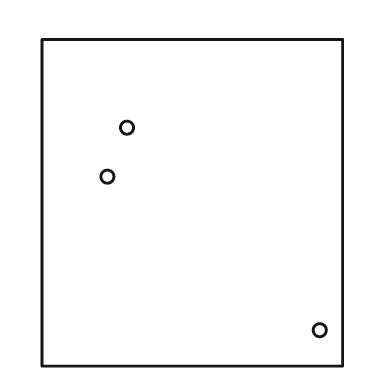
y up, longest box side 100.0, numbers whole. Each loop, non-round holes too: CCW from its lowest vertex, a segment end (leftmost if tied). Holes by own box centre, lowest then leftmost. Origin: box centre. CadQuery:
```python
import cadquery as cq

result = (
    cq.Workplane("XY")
    .moveTo(-46.0, -50.0)
    .lineTo(46.0, -50.0)
    .lineTo(46.0, 50.0)
    .lineTo(-46.0, 50.0)
    .close()
    .moveTo(39.0, -39.0)
    .circle(2.0)
    .moveTo(-26.0, 8.0)
    .circle(2.0)
    .moveTo(-20.0, 23.0)
    .circle(2.0)
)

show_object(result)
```